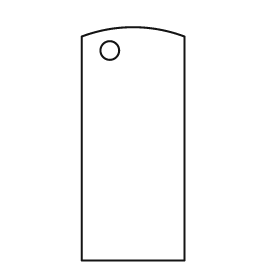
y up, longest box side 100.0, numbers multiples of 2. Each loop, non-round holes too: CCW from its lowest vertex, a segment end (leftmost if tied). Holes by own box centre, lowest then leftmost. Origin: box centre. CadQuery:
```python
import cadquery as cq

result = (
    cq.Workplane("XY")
    .moveTo(-22.0, -50.0)
    .lineTo(22.0, -50.0)
    .lineTo(22.0, 46.0)
    .threePointArc((0.0, 50.0), (-22.0, 46.0))
    .close()
    .moveTo(-10.0, 40.0)
    .circle(4.0)
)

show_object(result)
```